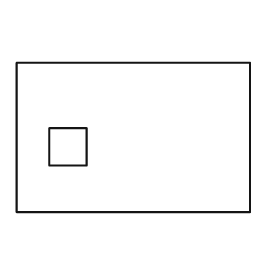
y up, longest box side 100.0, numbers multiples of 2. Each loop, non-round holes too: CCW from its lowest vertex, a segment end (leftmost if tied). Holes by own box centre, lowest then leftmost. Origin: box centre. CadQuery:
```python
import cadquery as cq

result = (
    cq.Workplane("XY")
    .moveTo(-50.0, -32.0)
    .lineTo(50.0, -32.0)
    .lineTo(50.0, 32.0)
    .lineTo(-50.0, 32.0)
    .close()
    .moveTo(-36.0, -12.0)
    .lineTo(-20.0, -12.0)
    .lineTo(-20.0, 4.0)
    .lineTo(-36.0, 4.0)
    .close()
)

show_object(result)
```